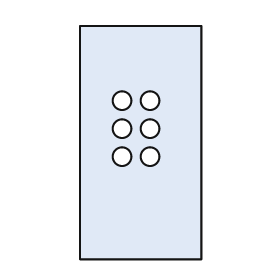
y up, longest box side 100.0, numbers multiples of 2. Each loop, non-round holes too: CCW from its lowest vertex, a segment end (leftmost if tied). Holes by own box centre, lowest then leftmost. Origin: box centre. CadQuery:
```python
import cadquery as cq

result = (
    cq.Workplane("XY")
    .moveTo(-26.0, -50.0)
    .lineTo(26.0, -50.0)
    .lineTo(26.0, 50.0)
    .lineTo(-26.0, 50.0)
    .close()
    .moveTo(-8.0, -6.0)
    .circle(4.0)
    .moveTo(4.0, -6.0)
    .circle(4.0)
    .moveTo(-8.0, 6.0)
    .circle(4.0)
    .moveTo(4.0, 6.0)
    .circle(4.0)
    .moveTo(-8.0, 18.0)
    .circle(4.0)
    .moveTo(4.0, 18.0)
    .circle(4.0)
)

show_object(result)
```